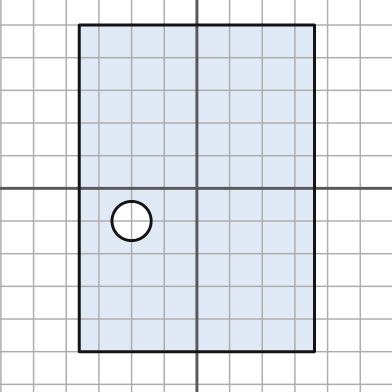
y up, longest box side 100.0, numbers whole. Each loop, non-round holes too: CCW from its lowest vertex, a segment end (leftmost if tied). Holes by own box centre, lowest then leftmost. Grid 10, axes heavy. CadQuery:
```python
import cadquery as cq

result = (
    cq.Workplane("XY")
    .moveTo(-36.0, -50.0)
    .lineTo(36.0, -50.0)
    .lineTo(36.0, 50.0)
    .lineTo(-36.0, 50.0)
    .close()
    .moveTo(-20.0, -10.0)
    .circle(6.0)
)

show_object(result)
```